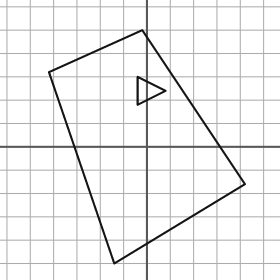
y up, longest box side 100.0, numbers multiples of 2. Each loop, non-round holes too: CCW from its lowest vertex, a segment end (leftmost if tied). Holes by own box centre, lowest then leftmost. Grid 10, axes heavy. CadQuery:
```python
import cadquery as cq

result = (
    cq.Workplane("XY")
    .moveTo(-14.0, -50.0)
    .lineTo(42.0, -16.0)
    .lineTo(-2.0, 50.0)
    .lineTo(-42.0, 32.0)
    .close()
    .moveTo(-4.0, 18.0)
    .lineTo(8.0, 24.0)
    .lineTo(-4.0, 30.0)
    .close()
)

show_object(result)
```